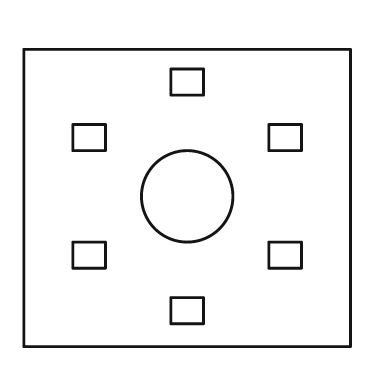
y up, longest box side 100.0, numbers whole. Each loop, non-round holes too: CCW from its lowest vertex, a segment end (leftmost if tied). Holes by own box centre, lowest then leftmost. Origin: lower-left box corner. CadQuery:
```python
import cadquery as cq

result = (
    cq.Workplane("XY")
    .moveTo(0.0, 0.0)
    .lineTo(100.0, 0.0)
    .lineTo(100.0, 91.0)
    .lineTo(0.0, 91.0)
    .close()
    .moveTo(45.0, 7.0)
    .lineTo(55.0, 7.0)
    .lineTo(55.0, 15.0)
    .lineTo(45.0, 15.0)
    .close()
    .moveTo(15.0, 24.0)
    .lineTo(25.0, 24.0)
    .lineTo(25.0, 32.0)
    .lineTo(15.0, 32.0)
    .close()
    .moveTo(75.0, 24.0)
    .lineTo(85.0, 24.0)
    .lineTo(85.0, 32.0)
    .lineTo(75.0, 32.0)
    .close()
    .moveTo(50.0, 46.0)
    .circle(14.0)
    .moveTo(15.0, 60.0)
    .lineTo(25.0, 60.0)
    .lineTo(25.0, 68.0)
    .lineTo(15.0, 68.0)
    .close()
    .moveTo(75.0, 60.0)
    .lineTo(85.0, 60.0)
    .lineTo(85.0, 68.0)
    .lineTo(75.0, 68.0)
    .close()
    .moveTo(45.0, 77.0)
    .lineTo(55.0, 77.0)
    .lineTo(55.0, 85.0)
    .lineTo(45.0, 85.0)
    .close()
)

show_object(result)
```